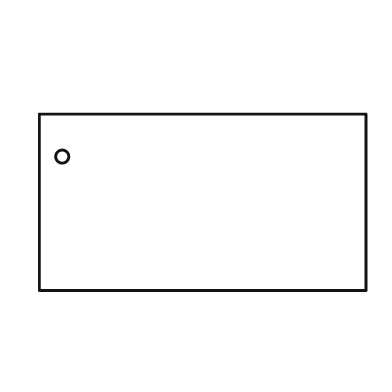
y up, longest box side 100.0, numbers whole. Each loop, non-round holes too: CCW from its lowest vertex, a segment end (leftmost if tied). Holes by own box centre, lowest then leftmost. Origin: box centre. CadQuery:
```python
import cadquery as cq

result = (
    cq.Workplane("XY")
    .moveTo(-50.0, -27.0)
    .lineTo(50.0, -27.0)
    .lineTo(50.0, 27.0)
    .lineTo(-50.0, 27.0)
    .close()
    .moveTo(-43.0, 14.0)
    .circle(2.0)
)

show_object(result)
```